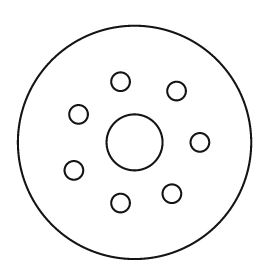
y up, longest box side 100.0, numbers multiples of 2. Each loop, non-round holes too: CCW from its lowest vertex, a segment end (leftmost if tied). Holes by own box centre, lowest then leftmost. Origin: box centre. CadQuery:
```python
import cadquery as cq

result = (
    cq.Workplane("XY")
    .moveTo(0.0, 0.0)
    .circle(50.0)
    .moveTo(-6.0, -26.0)
    .circle(4.0)
    .moveTo(16.0, -22.0)
    .circle(4.0)
    .moveTo(-26.0, -12.0)
    .circle(4.0)
    .moveTo(0.0, 0.0)
    .circle(12.0)
    .moveTo(28.0, 0.0)
    .circle(4.0)
    .moveTo(-24.0, 12.0)
    .circle(4.0)
    .moveTo(18.0, 22.0)
    .circle(4.0)
    .moveTo(-6.0, 26.0)
    .circle(4.0)
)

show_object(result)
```